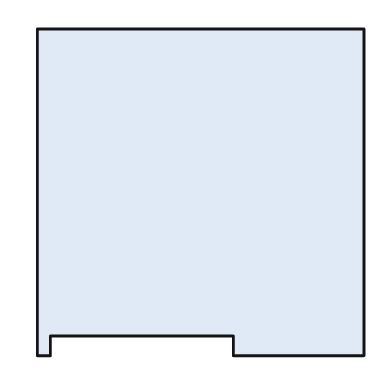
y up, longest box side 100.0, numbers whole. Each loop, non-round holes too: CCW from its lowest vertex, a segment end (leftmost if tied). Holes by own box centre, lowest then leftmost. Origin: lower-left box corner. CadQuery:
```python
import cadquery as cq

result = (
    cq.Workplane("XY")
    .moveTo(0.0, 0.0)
    .lineTo(4.0, 0.0)
    .lineTo(4.0, 6.0)
    .lineTo(60.0, 6.0)
    .lineTo(60.0, 0.0)
    .lineTo(100.0, 0.0)
    .lineTo(100.0, 100.0)
    .lineTo(0.0, 100.0)
    .close()
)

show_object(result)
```